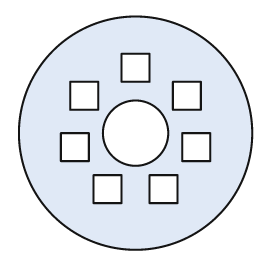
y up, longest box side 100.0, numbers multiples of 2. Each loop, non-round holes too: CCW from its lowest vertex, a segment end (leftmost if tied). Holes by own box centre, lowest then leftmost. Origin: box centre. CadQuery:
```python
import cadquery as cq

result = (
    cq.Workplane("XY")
    .moveTo(0.0, 0.0)
    .circle(50.0)
    .moveTo(-18.0, -30.0)
    .lineTo(-6.0, -30.0)
    .lineTo(-6.0, -18.0)
    .lineTo(-18.0, -18.0)
    .close()
    .moveTo(6.0, -30.0)
    .lineTo(18.0, -30.0)
    .lineTo(18.0, -18.0)
    .lineTo(6.0, -18.0)
    .close()
    .moveTo(-32.0, -12.0)
    .lineTo(-20.0, -12.0)
    .lineTo(-20.0, 0.0)
    .lineTo(-32.0, 0.0)
    .close()
    .moveTo(20.0, -12.0)
    .lineTo(32.0, -12.0)
    .lineTo(32.0, 0.0)
    .lineTo(20.0, 0.0)
    .close()
    .moveTo(0.0, 0.0)
    .circle(14.0)
    .moveTo(-28.0, 10.0)
    .lineTo(-16.0, 10.0)
    .lineTo(-16.0, 22.0)
    .lineTo(-28.0, 22.0)
    .close()
    .moveTo(16.0, 10.0)
    .lineTo(28.0, 10.0)
    .lineTo(28.0, 22.0)
    .lineTo(16.0, 22.0)
    .close()
    .moveTo(-6.0, 22.0)
    .lineTo(6.0, 22.0)
    .lineTo(6.0, 34.0)
    .lineTo(-6.0, 34.0)
    .close()
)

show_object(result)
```